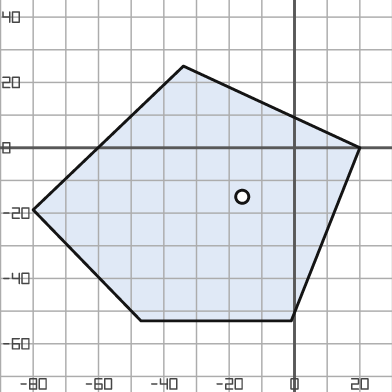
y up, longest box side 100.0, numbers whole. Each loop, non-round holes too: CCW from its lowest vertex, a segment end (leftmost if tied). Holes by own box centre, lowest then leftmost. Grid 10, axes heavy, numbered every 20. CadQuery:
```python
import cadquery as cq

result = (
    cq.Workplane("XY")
    .moveTo(-47.0, -53.0)
    .lineTo(-1.0, -53.0)
    .lineTo(20.0, 0.0)
    .lineTo(-34.0, 25.0)
    .lineTo(-80.0, -19.0)
    .close()
    .moveTo(-16.0, -15.0)
    .circle(2.0)
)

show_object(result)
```